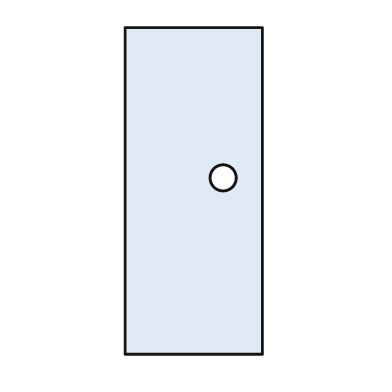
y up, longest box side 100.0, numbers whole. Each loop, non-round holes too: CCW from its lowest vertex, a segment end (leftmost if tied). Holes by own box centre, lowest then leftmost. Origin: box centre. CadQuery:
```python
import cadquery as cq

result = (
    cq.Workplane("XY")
    .moveTo(-21.0, -50.0)
    .lineTo(21.0, -50.0)
    .lineTo(21.0, 50.0)
    .lineTo(-21.0, 50.0)
    .close()
    .moveTo(9.0, 4.0)
    .circle(4.0)
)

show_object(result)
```